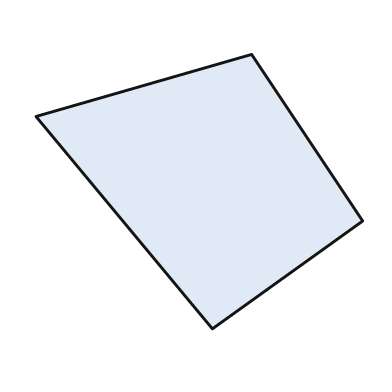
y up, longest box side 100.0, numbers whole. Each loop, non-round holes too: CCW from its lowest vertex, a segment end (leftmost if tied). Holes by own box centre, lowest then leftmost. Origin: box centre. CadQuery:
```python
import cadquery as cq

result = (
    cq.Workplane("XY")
    .moveTo(4.0, -42.0)
    .lineTo(50.0, -9.0)
    .lineTo(16.0, 42.0)
    .lineTo(-50.0, 23.0)
    .close()
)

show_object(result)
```